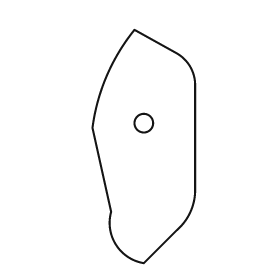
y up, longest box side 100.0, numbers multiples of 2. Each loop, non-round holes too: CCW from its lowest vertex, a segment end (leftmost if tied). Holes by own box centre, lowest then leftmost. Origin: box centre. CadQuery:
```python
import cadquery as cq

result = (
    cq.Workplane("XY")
    .moveTo(0.0, -50.0)
    .lineTo(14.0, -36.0)
    .threePointArc((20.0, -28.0), (22.0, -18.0))
    .lineTo(22.0, 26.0)
    .threePointArc((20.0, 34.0), (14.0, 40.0))
    .lineTo(-4.0, 50.0)
    .threePointArc((-16.0, 30.0), (-22.0, 8.0))
    .lineTo(-14.0, -28.0)
    .threePointArc((-12.0, -42.0), (0.0, -50.0))
    .close()
    .moveTo(0.0, 10.0)
    .circle(4.0)
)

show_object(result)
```